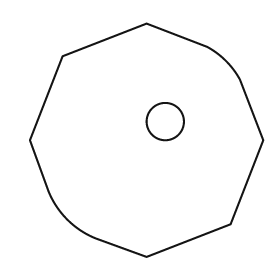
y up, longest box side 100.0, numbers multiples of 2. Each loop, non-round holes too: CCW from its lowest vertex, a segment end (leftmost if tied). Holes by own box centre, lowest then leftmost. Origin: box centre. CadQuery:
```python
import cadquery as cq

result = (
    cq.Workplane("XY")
    .moveTo(0.0, -50.0)
    .lineTo(36.0, -36.0)
    .lineTo(50.0, 0.0)
    .lineTo(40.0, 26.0)
    .threePointArc((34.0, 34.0), (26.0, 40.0))
    .lineTo(0.0, 50.0)
    .lineTo(-36.0, 36.0)
    .lineTo(-50.0, 0.0)
    .lineTo(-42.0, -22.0)
    .threePointArc((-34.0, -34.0), (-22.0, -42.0))
    .close()
    .moveTo(8.0, 8.0)
    .circle(8.0)
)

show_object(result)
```